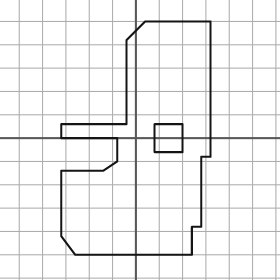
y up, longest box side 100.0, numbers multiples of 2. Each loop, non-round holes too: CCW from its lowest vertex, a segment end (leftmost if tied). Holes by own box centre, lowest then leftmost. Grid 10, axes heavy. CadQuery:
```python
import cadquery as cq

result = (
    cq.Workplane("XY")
    .moveTo(-26.0, -50.0)
    .lineTo(24.0, -50.0)
    .lineTo(24.0, -38.0)
    .lineTo(28.0, -38.0)
    .lineTo(28.0, -8.0)
    .lineTo(32.0, -8.0)
    .lineTo(32.0, 50.0)
    .lineTo(4.0, 50.0)
    .lineTo(-4.0, 42.0)
    .lineTo(-4.0, 6.0)
    .lineTo(-32.0, 6.0)
    .lineTo(-32.0, 0.0)
    .lineTo(-8.0, 0.0)
    .lineTo(-8.0, -10.0)
    .lineTo(-14.0, -14.0)
    .lineTo(-32.0, -14.0)
    .lineTo(-32.0, -42.0)
    .close()
    .moveTo(8.0, -6.0)
    .lineTo(20.0, -6.0)
    .lineTo(20.0, 6.0)
    .lineTo(8.0, 6.0)
    .close()
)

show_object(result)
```